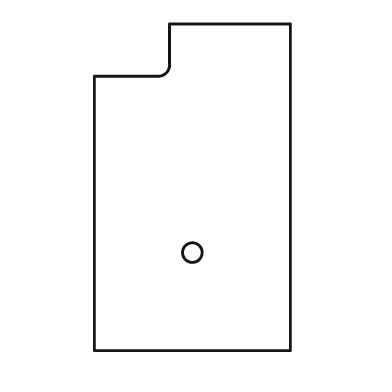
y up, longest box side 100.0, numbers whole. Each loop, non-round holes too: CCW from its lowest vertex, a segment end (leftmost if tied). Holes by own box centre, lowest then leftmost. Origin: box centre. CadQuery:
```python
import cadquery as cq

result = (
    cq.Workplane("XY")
    .moveTo(-30.0, -50.0)
    .lineTo(30.0, -50.0)
    .lineTo(30.0, 50.0)
    .lineTo(-7.0, 50.0)
    .lineTo(-7.0, 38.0)
    .threePointArc((-8.0, 35.0), (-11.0, 34.0))
    .lineTo(-30.0, 34.0)
    .close()
    .moveTo(0.0, -20.0)
    .circle(3.0)
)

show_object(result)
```